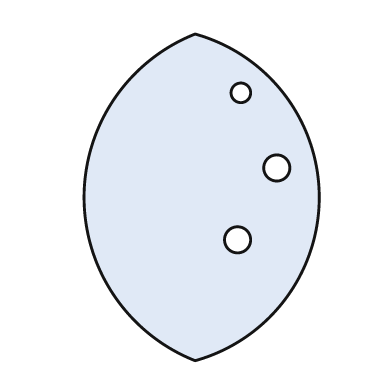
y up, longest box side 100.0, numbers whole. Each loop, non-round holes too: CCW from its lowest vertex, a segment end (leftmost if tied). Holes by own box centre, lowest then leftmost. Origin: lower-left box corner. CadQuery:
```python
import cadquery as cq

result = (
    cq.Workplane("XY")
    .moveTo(34.0, 0.0)
    .threePointArc((72.0, 50.0), (34.0, 100.0))
    .threePointArc((0.0, 50.0), (34.0, 0.0))
    .close()
    .moveTo(47.0, 37.0)
    .circle(4.0)
    .moveTo(59.0, 59.0)
    .circle(4.0)
    .moveTo(48.0, 82.0)
    .circle(3.0)
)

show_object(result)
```